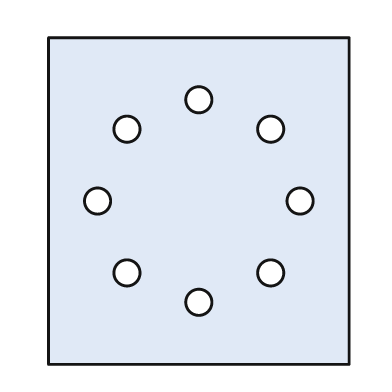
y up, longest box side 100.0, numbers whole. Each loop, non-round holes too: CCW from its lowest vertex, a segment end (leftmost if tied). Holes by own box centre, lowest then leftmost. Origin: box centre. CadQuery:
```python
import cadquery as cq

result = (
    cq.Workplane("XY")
    .moveTo(-46.0, -50.0)
    .lineTo(46.0, -50.0)
    .lineTo(46.0, 50.0)
    .lineTo(-46.0, 50.0)
    .close()
    .moveTo(0.0, -31.0)
    .circle(4.0)
    .moveTo(-22.0, -22.0)
    .circle(4.0)
    .moveTo(22.0, -22.0)
    .circle(4.0)
    .moveTo(-31.0, 0.0)
    .circle(4.0)
    .moveTo(31.0, 0.0)
    .circle(4.0)
    .moveTo(-22.0, 22.0)
    .circle(4.0)
    .moveTo(22.0, 22.0)
    .circle(4.0)
    .moveTo(0.0, 31.0)
    .circle(4.0)
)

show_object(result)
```